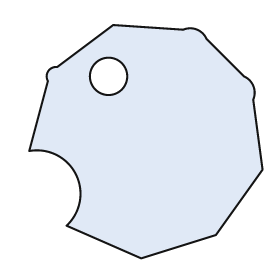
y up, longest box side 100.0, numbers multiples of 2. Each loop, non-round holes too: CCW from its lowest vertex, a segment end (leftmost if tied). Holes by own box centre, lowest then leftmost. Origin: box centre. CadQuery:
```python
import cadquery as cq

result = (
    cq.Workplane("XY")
    .moveTo(-2.0, -50.0)
    .lineTo(30.0, -40.0)
    .lineTo(50.0, -12.0)
    .lineTo(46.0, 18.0)
    .threePointArc((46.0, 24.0), (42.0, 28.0))
    .lineTo(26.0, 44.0)
    .threePointArc((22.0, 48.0), (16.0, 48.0))
    .lineTo(-14.0, 50.0)
    .lineTo(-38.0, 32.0)
    .threePointArc((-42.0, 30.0), (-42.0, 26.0))
    .lineTo(-50.0, -4.0)
    .threePointArc((-30.0, -14.0), (-34.0, -36.0))
    .close()
    .moveTo(-16.0, 28.0)
    .circle(8.0)
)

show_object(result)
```